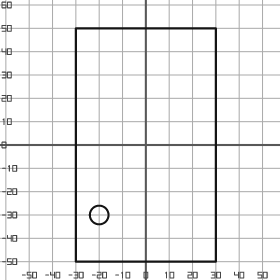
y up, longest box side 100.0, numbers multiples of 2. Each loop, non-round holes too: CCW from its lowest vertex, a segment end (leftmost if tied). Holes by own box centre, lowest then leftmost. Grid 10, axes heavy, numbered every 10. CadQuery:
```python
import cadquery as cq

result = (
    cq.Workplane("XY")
    .moveTo(-30.0, -50.0)
    .lineTo(30.0, -50.0)
    .lineTo(30.0, 50.0)
    .lineTo(-30.0, 50.0)
    .close()
    .moveTo(-20.0, -30.0)
    .circle(4.0)
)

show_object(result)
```